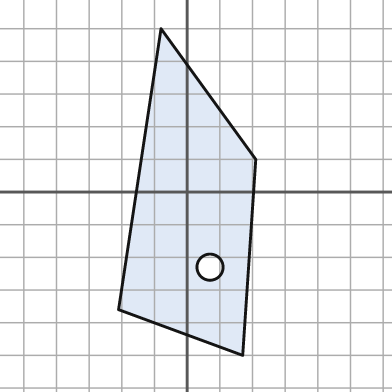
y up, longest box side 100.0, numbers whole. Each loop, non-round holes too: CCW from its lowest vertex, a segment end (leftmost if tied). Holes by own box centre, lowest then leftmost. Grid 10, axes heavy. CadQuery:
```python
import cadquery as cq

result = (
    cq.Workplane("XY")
    .moveTo(17.0, -50.0)
    .lineTo(21.0, 10.0)
    .lineTo(-8.0, 50.0)
    .lineTo(-21.0, -36.0)
    .close()
    .moveTo(7.0, -23.0)
    .circle(4.0)
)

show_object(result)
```